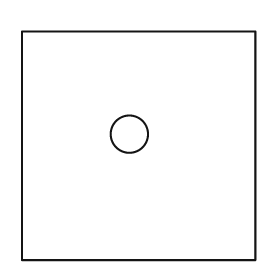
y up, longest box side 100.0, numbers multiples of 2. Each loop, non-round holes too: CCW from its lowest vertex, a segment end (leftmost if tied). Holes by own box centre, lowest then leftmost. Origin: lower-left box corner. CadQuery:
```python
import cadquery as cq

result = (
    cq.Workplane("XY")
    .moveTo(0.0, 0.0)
    .lineTo(100.0, 0.0)
    .lineTo(100.0, 98.0)
    .lineTo(0.0, 98.0)
    .close()
    .moveTo(46.0, 54.0)
    .circle(8.0)
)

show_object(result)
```